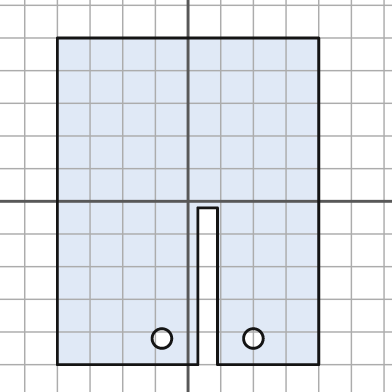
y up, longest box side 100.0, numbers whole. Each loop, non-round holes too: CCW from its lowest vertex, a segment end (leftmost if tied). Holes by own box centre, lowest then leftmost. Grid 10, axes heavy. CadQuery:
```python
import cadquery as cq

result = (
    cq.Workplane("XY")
    .moveTo(-40.0, -50.0)
    .lineTo(3.0, -50.0)
    .lineTo(3.0, -2.0)
    .lineTo(9.0, -2.0)
    .lineTo(9.0, -50.0)
    .lineTo(40.0, -50.0)
    .lineTo(40.0, 50.0)
    .lineTo(-40.0, 50.0)
    .close()
    .moveTo(-8.0, -42.0)
    .circle(3.0)
    .moveTo(20.0, -42.0)
    .circle(3.0)
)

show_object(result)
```